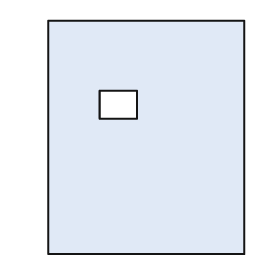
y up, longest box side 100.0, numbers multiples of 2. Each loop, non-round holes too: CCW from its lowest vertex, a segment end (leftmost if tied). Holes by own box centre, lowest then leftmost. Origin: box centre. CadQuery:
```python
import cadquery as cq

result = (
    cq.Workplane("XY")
    .moveTo(-42.0, -50.0)
    .lineTo(42.0, -50.0)
    .lineTo(42.0, 50.0)
    .lineTo(-42.0, 50.0)
    .close()
    .moveTo(-20.0, 8.0)
    .lineTo(-4.0, 8.0)
    .lineTo(-4.0, 20.0)
    .lineTo(-20.0, 20.0)
    .close()
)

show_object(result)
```